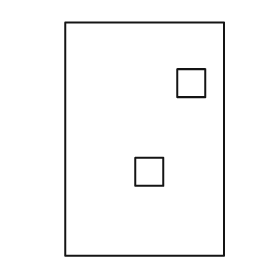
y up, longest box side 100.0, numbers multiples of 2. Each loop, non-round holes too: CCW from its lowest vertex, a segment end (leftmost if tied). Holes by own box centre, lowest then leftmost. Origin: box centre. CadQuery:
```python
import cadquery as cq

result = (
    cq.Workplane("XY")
    .moveTo(-34.0, -50.0)
    .lineTo(34.0, -50.0)
    .lineTo(34.0, 50.0)
    .lineTo(-34.0, 50.0)
    .close()
    .moveTo(-4.0, -20.0)
    .lineTo(8.0, -20.0)
    .lineTo(8.0, -8.0)
    .lineTo(-4.0, -8.0)
    .close()
    .moveTo(14.0, 18.0)
    .lineTo(26.0, 18.0)
    .lineTo(26.0, 30.0)
    .lineTo(14.0, 30.0)
    .close()
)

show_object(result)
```